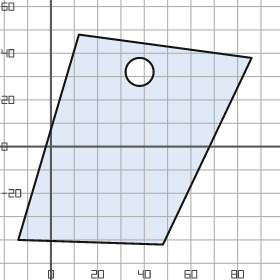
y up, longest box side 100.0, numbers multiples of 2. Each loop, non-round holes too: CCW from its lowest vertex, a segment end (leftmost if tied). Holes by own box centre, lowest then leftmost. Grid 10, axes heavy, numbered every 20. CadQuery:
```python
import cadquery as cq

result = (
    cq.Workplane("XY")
    .moveTo(48.0, -42.0)
    .lineTo(86.0, 38.0)
    .lineTo(12.0, 48.0)
    .lineTo(-14.0, -40.0)
    .close()
    .moveTo(38.0, 32.0)
    .circle(6.0)
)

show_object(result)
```